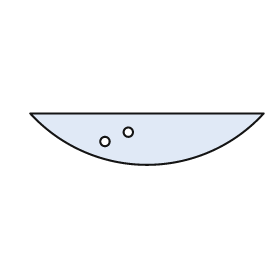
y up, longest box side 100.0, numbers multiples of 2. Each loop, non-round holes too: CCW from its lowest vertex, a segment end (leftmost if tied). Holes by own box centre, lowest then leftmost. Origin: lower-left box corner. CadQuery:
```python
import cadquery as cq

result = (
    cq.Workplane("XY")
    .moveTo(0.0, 22.0)
    .threePointArc((50.0, 0.0), (100.0, 22.0))
    .close()
    .moveTo(32.0, 10.0)
    .circle(2.0)
    .moveTo(42.0, 14.0)
    .circle(2.0)
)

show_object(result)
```